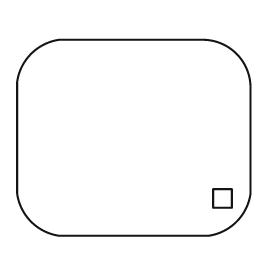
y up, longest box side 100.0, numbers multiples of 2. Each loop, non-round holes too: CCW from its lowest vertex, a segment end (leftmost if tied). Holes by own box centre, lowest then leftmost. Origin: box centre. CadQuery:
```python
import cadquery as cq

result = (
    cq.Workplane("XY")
    .moveTo(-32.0, -42.0)
    .lineTo(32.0, -42.0)
    .threePointArc((44.0, -36.0), (50.0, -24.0))
    .lineTo(50.0, 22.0)
    .threePointArc((44.0, 36.0), (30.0, 42.0))
    .lineTo(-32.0, 42.0)
    .threePointArc((-44.0, 36.0), (-50.0, 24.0))
    .lineTo(-50.0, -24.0)
    .threePointArc((-44.0, -36.0), (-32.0, -42.0))
    .close()
    .moveTo(34.0, -30.0)
    .lineTo(42.0, -30.0)
    .lineTo(42.0, -22.0)
    .lineTo(34.0, -22.0)
    .close()
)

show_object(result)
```